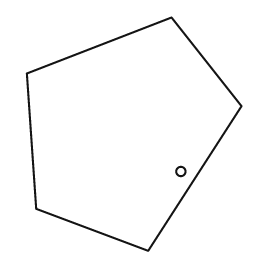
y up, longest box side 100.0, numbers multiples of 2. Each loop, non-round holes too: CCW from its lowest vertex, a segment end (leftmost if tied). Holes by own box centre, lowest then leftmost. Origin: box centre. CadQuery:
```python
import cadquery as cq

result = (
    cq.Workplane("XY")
    .moveTo(6.0, -50.0)
    .lineTo(46.0, 12.0)
    .lineTo(16.0, 50.0)
    .lineTo(-46.0, 26.0)
    .lineTo(-42.0, -32.0)
    .close()
    .moveTo(20.0, -16.0)
    .circle(2.0)
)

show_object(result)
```